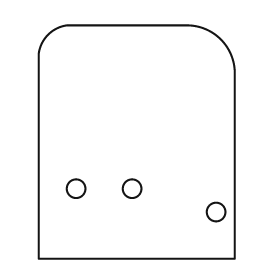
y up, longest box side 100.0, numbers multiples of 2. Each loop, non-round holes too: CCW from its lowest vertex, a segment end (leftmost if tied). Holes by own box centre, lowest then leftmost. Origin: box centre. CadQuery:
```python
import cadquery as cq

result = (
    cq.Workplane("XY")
    .moveTo(-42.0, -50.0)
    .lineTo(42.0, -50.0)
    .lineTo(42.0, 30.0)
    .threePointArc((36.0, 44.0), (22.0, 50.0))
    .lineTo(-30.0, 50.0)
    .threePointArc((-38.0, 46.0), (-42.0, 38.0))
    .close()
    .moveTo(34.0, -30.0)
    .circle(4.0)
    .moveTo(-26.0, -20.0)
    .circle(4.0)
    .moveTo(-2.0, -20.0)
    .circle(4.0)
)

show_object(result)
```